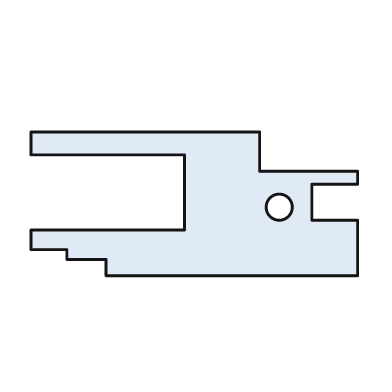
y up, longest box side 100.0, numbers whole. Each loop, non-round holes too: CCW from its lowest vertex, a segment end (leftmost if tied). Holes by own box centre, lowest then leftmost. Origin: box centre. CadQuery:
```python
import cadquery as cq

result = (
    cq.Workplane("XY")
    .moveTo(-27.0, -22.0)
    .lineTo(50.0, -22.0)
    .lineTo(50.0, -5.0)
    .lineTo(36.0, -5.0)
    .lineTo(36.0, 6.0)
    .lineTo(50.0, 6.0)
    .lineTo(50.0, 10.0)
    .lineTo(20.0, 10.0)
    .lineTo(20.0, 22.0)
    .lineTo(-50.0, 22.0)
    .lineTo(-50.0, 15.0)
    .lineTo(-3.0, 15.0)
    .lineTo(-3.0, -8.0)
    .lineTo(-50.0, -8.0)
    .lineTo(-50.0, -14.0)
    .lineTo(-39.0, -14.0)
    .lineTo(-39.0, -17.0)
    .lineTo(-27.0, -17.0)
    .close()
    .moveTo(26.0, -1.0)
    .circle(4.0)
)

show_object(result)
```